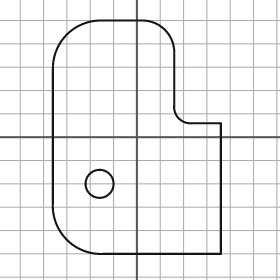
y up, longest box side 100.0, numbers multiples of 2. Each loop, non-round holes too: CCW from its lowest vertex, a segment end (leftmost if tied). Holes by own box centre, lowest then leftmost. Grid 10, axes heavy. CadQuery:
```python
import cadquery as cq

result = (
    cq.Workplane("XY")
    .moveTo(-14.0, -50.0)
    .lineTo(36.0, -50.0)
    .lineTo(36.0, 6.0)
    .lineTo(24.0, 6.0)
    .threePointArc((18.0, 8.0), (16.0, 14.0))
    .lineTo(16.0, 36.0)
    .threePointArc((12.0, 46.0), (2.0, 50.0))
    .lineTo(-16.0, 50.0)
    .threePointArc((-30.0, 44.0), (-36.0, 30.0))
    .lineTo(-36.0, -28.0)
    .threePointArc((-30.0, -44.0), (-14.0, -50.0))
    .close()
    .moveTo(-16.0, -20.0)
    .circle(6.0)
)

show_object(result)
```